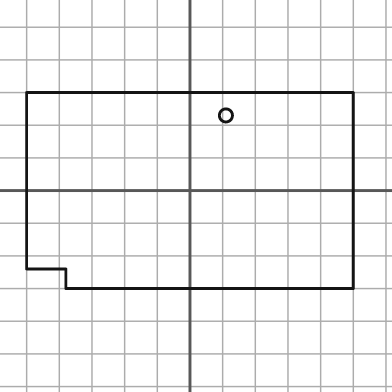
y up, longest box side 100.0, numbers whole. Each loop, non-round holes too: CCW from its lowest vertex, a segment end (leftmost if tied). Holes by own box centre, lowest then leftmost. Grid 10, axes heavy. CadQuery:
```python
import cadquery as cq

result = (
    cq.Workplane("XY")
    .moveTo(-38.0, -30.0)
    .lineTo(50.0, -30.0)
    .lineTo(50.0, 30.0)
    .lineTo(-50.0, 30.0)
    .lineTo(-50.0, -24.0)
    .lineTo(-38.0, -24.0)
    .close()
    .moveTo(11.0, 23.0)
    .circle(2.0)
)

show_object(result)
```